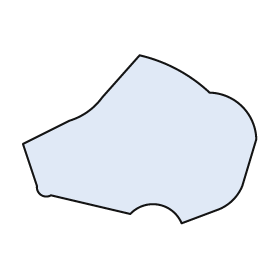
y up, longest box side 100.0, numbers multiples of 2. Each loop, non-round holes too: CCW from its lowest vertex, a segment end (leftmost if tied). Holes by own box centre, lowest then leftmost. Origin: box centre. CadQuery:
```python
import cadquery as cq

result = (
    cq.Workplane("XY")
    .moveTo(18.0, -36.0)
    .lineTo(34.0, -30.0)
    .threePointArc((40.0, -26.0), (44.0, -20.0))
    .lineTo(50.0, 0.0)
    .threePointArc((44.0, 14.0), (30.0, 20.0))
    .threePointArc((16.0, 30.0), (0.0, 36.0))
    .lineTo(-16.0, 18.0)
    .threePointArc((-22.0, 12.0), (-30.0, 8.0))
    .lineTo(-50.0, -2.0)
    .lineTo(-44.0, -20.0)
    .threePointArc((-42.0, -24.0), (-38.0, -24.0))
    .lineTo(-4.0, -32.0)
    .threePointArc((8.0, -28.0), (18.0, -36.0))
    .close()
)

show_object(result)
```